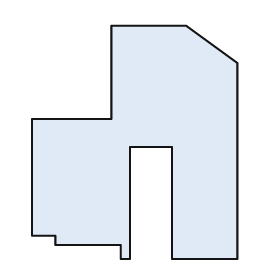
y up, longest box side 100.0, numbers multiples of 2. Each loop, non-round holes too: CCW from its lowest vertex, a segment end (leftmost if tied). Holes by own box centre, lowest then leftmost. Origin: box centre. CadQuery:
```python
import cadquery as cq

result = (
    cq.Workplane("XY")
    .moveTo(-6.0, -50.0)
    .lineTo(-2.0, -50.0)
    .lineTo(-2.0, -2.0)
    .lineTo(16.0, -2.0)
    .lineTo(16.0, -50.0)
    .lineTo(44.0, -50.0)
    .lineTo(44.0, 34.0)
    .lineTo(22.0, 50.0)
    .lineTo(-10.0, 50.0)
    .lineTo(-10.0, 10.0)
    .lineTo(-44.0, 10.0)
    .lineTo(-44.0, -40.0)
    .lineTo(-34.0, -40.0)
    .lineTo(-34.0, -44.0)
    .lineTo(-6.0, -44.0)
    .close()
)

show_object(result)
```